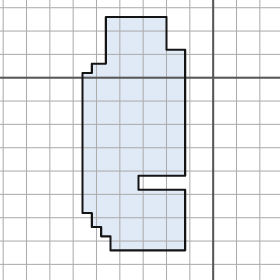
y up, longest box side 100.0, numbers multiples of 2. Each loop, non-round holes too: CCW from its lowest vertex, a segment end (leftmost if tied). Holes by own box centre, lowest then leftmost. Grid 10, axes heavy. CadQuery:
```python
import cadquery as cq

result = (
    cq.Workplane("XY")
    .moveTo(-44.0, -74.0)
    .lineTo(-12.0, -74.0)
    .lineTo(-12.0, -48.0)
    .lineTo(-32.0, -48.0)
    .lineTo(-32.0, -42.0)
    .lineTo(-12.0, -42.0)
    .lineTo(-12.0, 12.0)
    .lineTo(-20.0, 12.0)
    .lineTo(-20.0, 26.0)
    .lineTo(-46.0, 26.0)
    .lineTo(-46.0, 6.0)
    .lineTo(-52.0, 6.0)
    .lineTo(-52.0, 2.0)
    .lineTo(-56.0, 2.0)
    .lineTo(-56.0, -58.0)
    .lineTo(-52.0, -58.0)
    .lineTo(-52.0, -64.0)
    .lineTo(-48.0, -64.0)
    .lineTo(-48.0, -68.0)
    .lineTo(-44.0, -68.0)
    .close()
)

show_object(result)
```